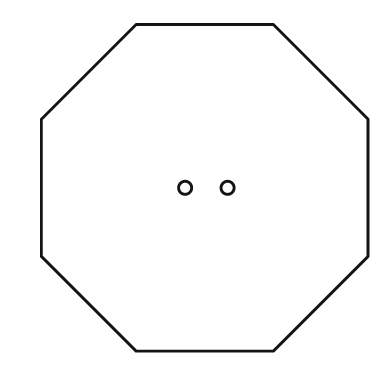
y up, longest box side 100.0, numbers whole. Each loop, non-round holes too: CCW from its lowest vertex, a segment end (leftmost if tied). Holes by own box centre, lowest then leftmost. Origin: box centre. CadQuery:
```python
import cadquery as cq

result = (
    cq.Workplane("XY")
    .moveTo(-21.0, -50.0)
    .lineTo(21.0, -50.0)
    .lineTo(50.0, -21.0)
    .lineTo(50.0, 21.0)
    .lineTo(21.0, 50.0)
    .lineTo(-21.0, 50.0)
    .lineTo(-50.0, 21.0)
    .lineTo(-50.0, -21.0)
    .close()
    .moveTo(-6.0, 0.0)
    .circle(2.0)
    .moveTo(7.0, 0.0)
    .circle(2.0)
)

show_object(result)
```